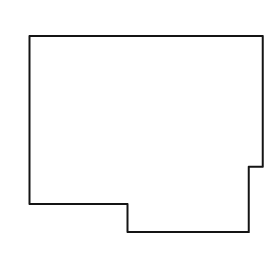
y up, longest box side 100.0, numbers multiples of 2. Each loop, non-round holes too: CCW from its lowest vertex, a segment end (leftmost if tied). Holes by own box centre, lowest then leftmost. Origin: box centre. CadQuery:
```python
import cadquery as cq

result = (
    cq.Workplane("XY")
    .moveTo(-8.0, -42.0)
    .lineTo(44.0, -42.0)
    .lineTo(44.0, -14.0)
    .lineTo(50.0, -14.0)
    .lineTo(50.0, 42.0)
    .lineTo(-50.0, 42.0)
    .lineTo(-50.0, -30.0)
    .lineTo(-8.0, -30.0)
    .close()
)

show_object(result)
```